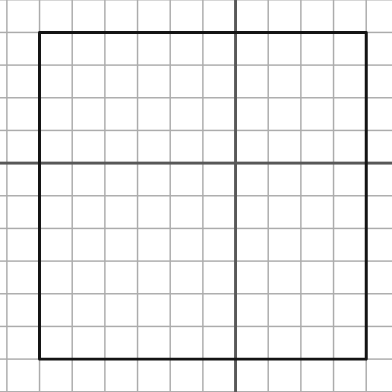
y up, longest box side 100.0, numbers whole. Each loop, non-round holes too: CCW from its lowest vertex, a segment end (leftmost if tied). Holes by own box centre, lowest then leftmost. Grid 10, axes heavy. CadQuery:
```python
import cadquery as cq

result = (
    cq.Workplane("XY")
    .moveTo(-60.0, -60.0)
    .lineTo(40.0, -60.0)
    .lineTo(40.0, 40.0)
    .lineTo(-60.0, 40.0)
    .close()
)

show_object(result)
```